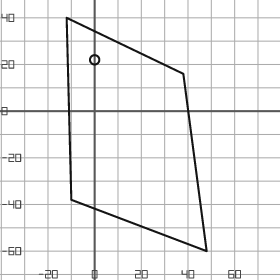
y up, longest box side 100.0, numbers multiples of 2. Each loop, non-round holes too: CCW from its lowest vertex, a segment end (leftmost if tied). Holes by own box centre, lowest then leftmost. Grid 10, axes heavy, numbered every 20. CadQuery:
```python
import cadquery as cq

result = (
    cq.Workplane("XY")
    .moveTo(48.0, -60.0)
    .lineTo(38.0, 16.0)
    .lineTo(-12.0, 40.0)
    .lineTo(-10.0, -38.0)
    .close()
    .moveTo(0.0, 22.0)
    .circle(2.0)
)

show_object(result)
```